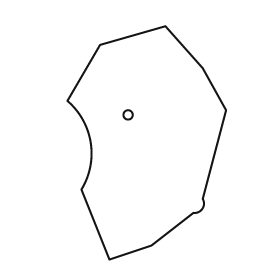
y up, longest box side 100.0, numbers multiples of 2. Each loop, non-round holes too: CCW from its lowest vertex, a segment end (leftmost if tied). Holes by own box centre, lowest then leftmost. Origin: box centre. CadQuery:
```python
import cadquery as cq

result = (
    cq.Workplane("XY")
    .moveTo(-16.0, -50.0)
    .lineTo(2.0, -44.0)
    .lineTo(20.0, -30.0)
    .threePointArc((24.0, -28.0), (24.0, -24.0))
    .lineTo(34.0, 14.0)
    .lineTo(24.0, 32.0)
    .lineTo(8.0, 50.0)
    .lineTo(-20.0, 42.0)
    .lineTo(-34.0, 18.0)
    .threePointArc((-24.0, 0.0), (-28.0, -20.0))
    .close()
    .moveTo(-8.0, 12.0)
    .circle(2.0)
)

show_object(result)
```